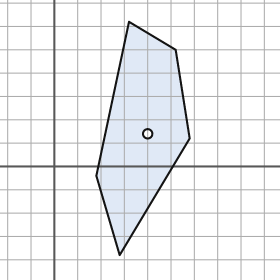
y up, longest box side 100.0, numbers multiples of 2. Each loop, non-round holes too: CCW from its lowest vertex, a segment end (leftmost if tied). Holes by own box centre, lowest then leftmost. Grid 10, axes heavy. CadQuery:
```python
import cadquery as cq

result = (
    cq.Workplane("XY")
    .moveTo(28.0, -38.0)
    .lineTo(58.0, 12.0)
    .lineTo(52.0, 50.0)
    .lineTo(32.0, 62.0)
    .lineTo(18.0, -4.0)
    .close()
    .moveTo(40.0, 14.0)
    .circle(2.0)
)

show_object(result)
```